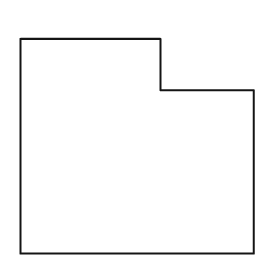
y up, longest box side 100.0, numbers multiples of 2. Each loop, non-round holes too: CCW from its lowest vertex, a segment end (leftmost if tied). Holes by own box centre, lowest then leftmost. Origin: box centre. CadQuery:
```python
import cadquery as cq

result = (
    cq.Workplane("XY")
    .moveTo(-50.0, -46.0)
    .lineTo(50.0, -46.0)
    .lineTo(50.0, 24.0)
    .lineTo(10.0, 24.0)
    .lineTo(10.0, 46.0)
    .lineTo(-50.0, 46.0)
    .close()
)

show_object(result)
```